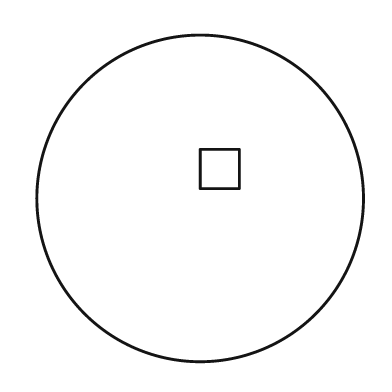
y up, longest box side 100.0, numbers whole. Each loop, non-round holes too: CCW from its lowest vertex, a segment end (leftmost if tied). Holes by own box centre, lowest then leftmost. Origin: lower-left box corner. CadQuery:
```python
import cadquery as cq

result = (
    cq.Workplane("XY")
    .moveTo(50.0, 50.0)
    .circle(50.0)
    .moveTo(50.0, 53.0)
    .lineTo(62.0, 53.0)
    .lineTo(62.0, 65.0)
    .lineTo(50.0, 65.0)
    .close()
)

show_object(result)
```